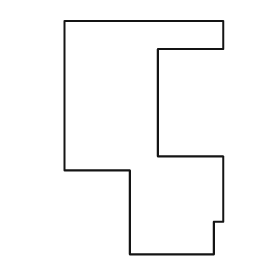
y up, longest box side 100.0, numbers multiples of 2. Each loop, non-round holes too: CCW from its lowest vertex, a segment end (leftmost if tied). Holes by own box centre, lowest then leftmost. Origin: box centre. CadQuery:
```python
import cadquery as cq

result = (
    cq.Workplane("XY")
    .moveTo(-6.0, -50.0)
    .lineTo(30.0, -50.0)
    .lineTo(30.0, -36.0)
    .lineTo(34.0, -36.0)
    .lineTo(34.0, -8.0)
    .lineTo(6.0, -8.0)
    .lineTo(6.0, 38.0)
    .lineTo(34.0, 38.0)
    .lineTo(34.0, 50.0)
    .lineTo(-34.0, 50.0)
    .lineTo(-34.0, -14.0)
    .lineTo(-6.0, -14.0)
    .close()
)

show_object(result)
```